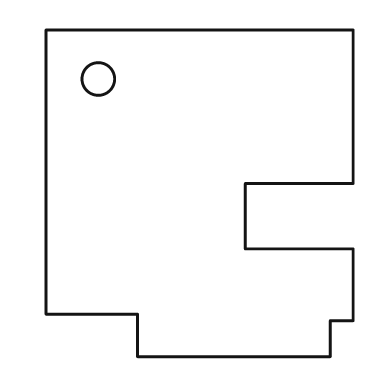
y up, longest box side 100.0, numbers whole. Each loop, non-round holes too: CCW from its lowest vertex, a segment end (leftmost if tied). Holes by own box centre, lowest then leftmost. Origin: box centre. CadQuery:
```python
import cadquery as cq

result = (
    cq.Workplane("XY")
    .moveTo(-19.0, -50.0)
    .lineTo(40.0, -50.0)
    .lineTo(40.0, -39.0)
    .lineTo(47.0, -39.0)
    .lineTo(47.0, -17.0)
    .lineTo(14.0, -17.0)
    .lineTo(14.0, 3.0)
    .lineTo(47.0, 3.0)
    .lineTo(47.0, 50.0)
    .lineTo(-47.0, 50.0)
    .lineTo(-47.0, -37.0)
    .lineTo(-19.0, -37.0)
    .close()
    .moveTo(-31.0, 35.0)
    .circle(5.0)
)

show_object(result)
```